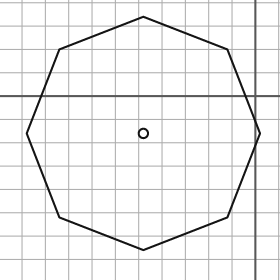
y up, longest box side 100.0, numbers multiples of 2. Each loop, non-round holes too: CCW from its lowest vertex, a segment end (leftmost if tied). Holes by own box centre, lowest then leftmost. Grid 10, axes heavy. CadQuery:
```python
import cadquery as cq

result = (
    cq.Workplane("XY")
    .moveTo(-48.0, -66.0)
    .lineTo(-12.0, -52.0)
    .lineTo(2.0, -16.0)
    .lineTo(-12.0, 20.0)
    .lineTo(-48.0, 34.0)
    .lineTo(-84.0, 20.0)
    .lineTo(-98.0, -16.0)
    .lineTo(-84.0, -52.0)
    .close()
    .moveTo(-48.0, -16.0)
    .circle(2.0)
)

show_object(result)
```